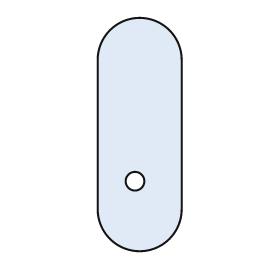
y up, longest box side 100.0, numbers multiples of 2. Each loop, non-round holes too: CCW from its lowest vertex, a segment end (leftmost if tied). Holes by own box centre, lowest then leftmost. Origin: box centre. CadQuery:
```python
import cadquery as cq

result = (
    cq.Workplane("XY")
    .moveTo(-18.0, -32.0)
    .threePointArc((0.0, -50.0), (18.0, -32.0))
    .lineTo(18.0, 32.0)
    .threePointArc((0.0, 50.0), (-18.0, 32.0))
    .close()
    .moveTo(-2.0, -20.0)
    .circle(4.0)
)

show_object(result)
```